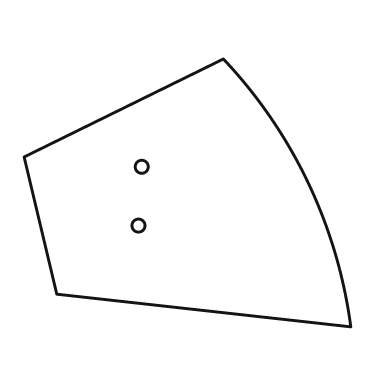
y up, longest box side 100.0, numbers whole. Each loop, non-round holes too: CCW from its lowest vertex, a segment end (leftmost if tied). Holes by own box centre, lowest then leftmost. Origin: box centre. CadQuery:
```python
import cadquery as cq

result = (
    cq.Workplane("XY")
    .moveTo(50.0, -41.0)
    .threePointArc((37.0, 3.0), (11.0, 41.0))
    .lineTo(-50.0, 11.0)
    .lineTo(-40.0, -31.0)
    .close()
    .moveTo(-15.0, -10.0)
    .circle(2.0)
    .moveTo(-14.0, 8.0)
    .circle(2.0)
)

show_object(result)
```